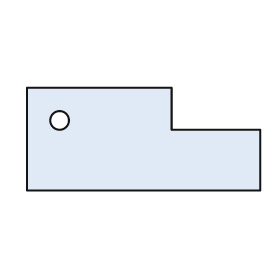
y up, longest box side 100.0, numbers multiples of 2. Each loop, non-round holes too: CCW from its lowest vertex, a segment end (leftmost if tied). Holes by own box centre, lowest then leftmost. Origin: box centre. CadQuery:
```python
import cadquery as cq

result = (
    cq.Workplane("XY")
    .moveTo(-50.0, -22.0)
    .lineTo(50.0, -22.0)
    .lineTo(50.0, 4.0)
    .lineTo(12.0, 4.0)
    .lineTo(12.0, 22.0)
    .lineTo(-50.0, 22.0)
    .close()
    .moveTo(-36.0, 8.0)
    .circle(4.0)
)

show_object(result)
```